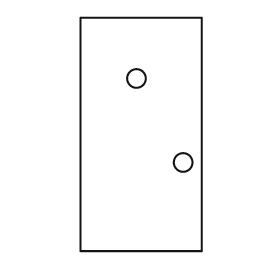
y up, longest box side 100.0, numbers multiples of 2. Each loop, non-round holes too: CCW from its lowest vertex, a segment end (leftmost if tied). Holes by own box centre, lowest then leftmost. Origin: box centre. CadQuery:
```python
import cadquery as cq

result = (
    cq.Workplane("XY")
    .moveTo(-26.0, -50.0)
    .lineTo(26.0, -50.0)
    .lineTo(26.0, 50.0)
    .lineTo(-26.0, 50.0)
    .close()
    .moveTo(18.0, -12.0)
    .circle(4.0)
    .moveTo(-2.0, 24.0)
    .circle(4.0)
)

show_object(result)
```